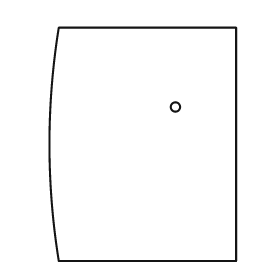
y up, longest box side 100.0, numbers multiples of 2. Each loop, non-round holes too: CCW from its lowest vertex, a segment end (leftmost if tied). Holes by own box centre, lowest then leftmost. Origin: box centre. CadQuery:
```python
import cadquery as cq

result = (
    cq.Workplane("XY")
    .moveTo(-36.0, -50.0)
    .lineTo(40.0, -50.0)
    .lineTo(40.0, 50.0)
    .lineTo(-36.0, 50.0)
    .threePointArc((-40.0, 0.0), (-36.0, -50.0))
    .close()
    .moveTo(14.0, 16.0)
    .circle(2.0)
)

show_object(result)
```